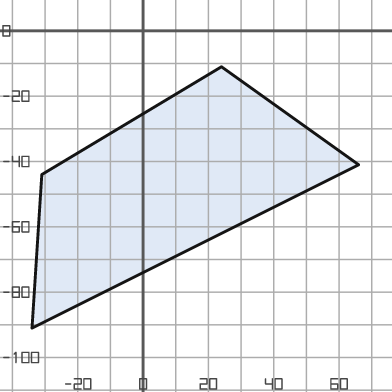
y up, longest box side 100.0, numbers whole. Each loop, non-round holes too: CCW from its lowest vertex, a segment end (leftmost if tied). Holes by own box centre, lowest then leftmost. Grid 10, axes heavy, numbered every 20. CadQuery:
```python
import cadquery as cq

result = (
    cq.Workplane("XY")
    .moveTo(-34.0, -91.0)
    .lineTo(66.0, -41.0)
    .lineTo(24.0, -11.0)
    .lineTo(-31.0, -44.0)
    .close()
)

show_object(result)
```